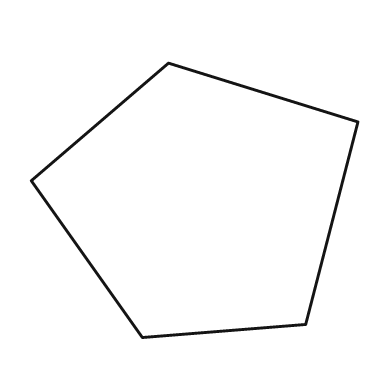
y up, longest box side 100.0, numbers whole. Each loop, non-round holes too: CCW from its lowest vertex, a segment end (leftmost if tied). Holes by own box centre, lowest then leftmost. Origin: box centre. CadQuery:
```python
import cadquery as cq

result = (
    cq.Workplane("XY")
    .moveTo(-16.0, -42.0)
    .lineTo(34.0, -38.0)
    .lineTo(50.0, 24.0)
    .lineTo(-8.0, 42.0)
    .lineTo(-50.0, 6.0)
    .close()
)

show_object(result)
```